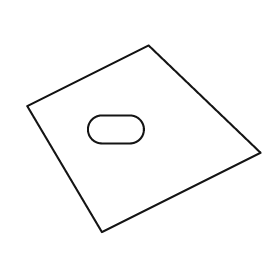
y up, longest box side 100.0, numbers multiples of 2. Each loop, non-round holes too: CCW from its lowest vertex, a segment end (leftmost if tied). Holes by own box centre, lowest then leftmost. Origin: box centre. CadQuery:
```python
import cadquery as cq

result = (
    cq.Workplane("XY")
    .moveTo(-18.0, -40.0)
    .lineTo(50.0, -6.0)
    .lineTo(2.0, 40.0)
    .lineTo(-50.0, 14.0)
    .close()
    .moveTo(-18.0, -2.0)
    .lineTo(-6.0, -2.0)
    .threePointArc((0.0, 4.0), (-6.0, 10.0))
    .lineTo(-18.0, 10.0)
    .threePointArc((-24.0, 4.0), (-18.0, -2.0))
    .close()
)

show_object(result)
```